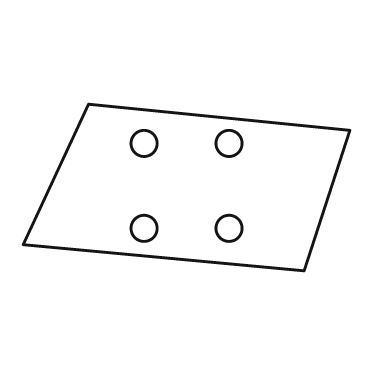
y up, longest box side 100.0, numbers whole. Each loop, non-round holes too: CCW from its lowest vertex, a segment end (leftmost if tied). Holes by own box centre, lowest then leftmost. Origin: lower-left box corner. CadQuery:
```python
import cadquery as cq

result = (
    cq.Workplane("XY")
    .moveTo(86.0, 0.0)
    .lineTo(100.0, 43.0)
    .lineTo(20.0, 51.0)
    .lineTo(0.0, 8.0)
    .close()
    .moveTo(37.0, 13.0)
    .circle(4.0)
    .moveTo(63.0, 13.0)
    .circle(4.0)
    .moveTo(37.0, 39.0)
    .circle(4.0)
    .moveTo(63.0, 39.0)
    .circle(4.0)
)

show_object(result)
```